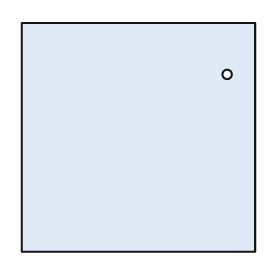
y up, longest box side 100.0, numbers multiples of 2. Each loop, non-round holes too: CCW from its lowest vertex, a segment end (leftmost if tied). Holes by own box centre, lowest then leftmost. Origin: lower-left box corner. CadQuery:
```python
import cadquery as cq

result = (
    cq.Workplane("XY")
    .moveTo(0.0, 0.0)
    .lineTo(100.0, 0.0)
    .lineTo(100.0, 98.0)
    .lineTo(0.0, 98.0)
    .close()
    .moveTo(88.0, 76.0)
    .circle(2.0)
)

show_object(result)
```